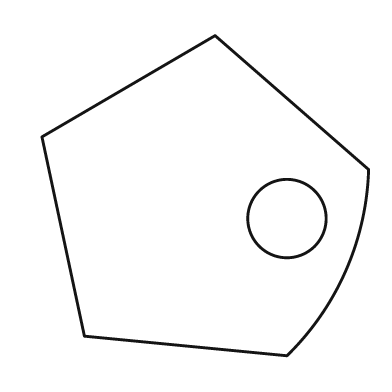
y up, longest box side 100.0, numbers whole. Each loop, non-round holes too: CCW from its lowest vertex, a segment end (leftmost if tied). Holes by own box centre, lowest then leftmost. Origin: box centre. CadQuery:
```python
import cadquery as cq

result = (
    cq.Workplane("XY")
    .moveTo(25.0, -49.0)
    .threePointArc((43.0, -23.0), (50.0, 8.0))
    .lineTo(3.0, 49.0)
    .lineTo(-50.0, 18.0)
    .lineTo(-37.0, -43.0)
    .close()
    .moveTo(25.0, -7.0)
    .circle(12.0)
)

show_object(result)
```